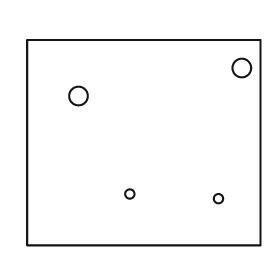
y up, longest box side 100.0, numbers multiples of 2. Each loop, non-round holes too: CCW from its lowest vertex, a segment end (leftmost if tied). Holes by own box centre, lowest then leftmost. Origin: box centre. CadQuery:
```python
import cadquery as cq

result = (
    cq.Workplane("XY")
    .moveTo(-50.0, -44.0)
    .lineTo(50.0, -44.0)
    .lineTo(50.0, 44.0)
    .lineTo(-50.0, 44.0)
    .close()
    .moveTo(32.0, -24.0)
    .circle(2.0)
    .moveTo(-6.0, -22.0)
    .circle(2.0)
    .moveTo(-28.0, 20.0)
    .circle(4.0)
    .moveTo(42.0, 32.0)
    .circle(4.0)
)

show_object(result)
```